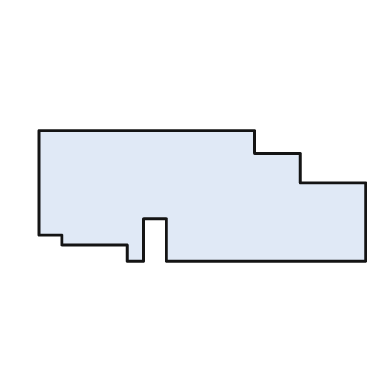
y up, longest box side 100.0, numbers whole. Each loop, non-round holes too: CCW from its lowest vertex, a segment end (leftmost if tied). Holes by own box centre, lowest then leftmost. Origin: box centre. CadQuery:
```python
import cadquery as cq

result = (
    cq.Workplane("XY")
    .moveTo(-23.0, -20.0)
    .lineTo(-18.0, -20.0)
    .lineTo(-18.0, -7.0)
    .lineTo(-11.0, -7.0)
    .lineTo(-11.0, -20.0)
    .lineTo(50.0, -20.0)
    .lineTo(50.0, 4.0)
    .lineTo(30.0, 4.0)
    .lineTo(30.0, 13.0)
    .lineTo(16.0, 13.0)
    .lineTo(16.0, 20.0)
    .lineTo(-50.0, 20.0)
    .lineTo(-50.0, -12.0)
    .lineTo(-43.0, -12.0)
    .lineTo(-43.0, -15.0)
    .lineTo(-23.0, -15.0)
    .close()
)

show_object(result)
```